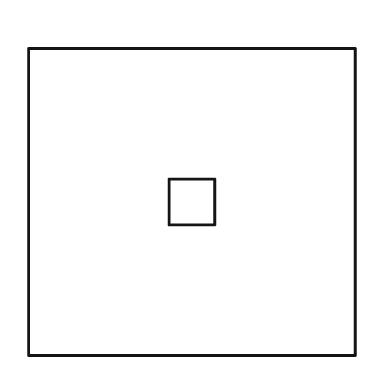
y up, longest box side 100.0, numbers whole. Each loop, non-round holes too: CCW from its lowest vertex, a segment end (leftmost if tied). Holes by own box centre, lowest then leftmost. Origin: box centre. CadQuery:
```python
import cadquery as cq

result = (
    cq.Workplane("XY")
    .moveTo(-50.0, -47.0)
    .lineTo(50.0, -47.0)
    .lineTo(50.0, 47.0)
    .lineTo(-50.0, 47.0)
    .close()
    .moveTo(-7.0, -7.0)
    .lineTo(7.0, -7.0)
    .lineTo(7.0, 7.0)
    .lineTo(-7.0, 7.0)
    .close()
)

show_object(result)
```